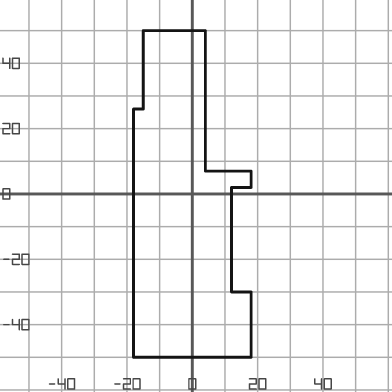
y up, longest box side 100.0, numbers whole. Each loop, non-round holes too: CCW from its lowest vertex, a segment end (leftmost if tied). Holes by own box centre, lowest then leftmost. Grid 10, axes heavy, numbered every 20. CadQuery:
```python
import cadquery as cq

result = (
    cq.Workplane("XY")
    .moveTo(-18.0, -50.0)
    .lineTo(18.0, -50.0)
    .lineTo(18.0, -30.0)
    .lineTo(12.0, -30.0)
    .lineTo(12.0, 2.0)
    .lineTo(18.0, 2.0)
    .lineTo(18.0, 7.0)
    .lineTo(4.0, 7.0)
    .lineTo(4.0, 50.0)
    .lineTo(-15.0, 50.0)
    .lineTo(-15.0, 26.0)
    .lineTo(-18.0, 26.0)
    .close()
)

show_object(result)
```